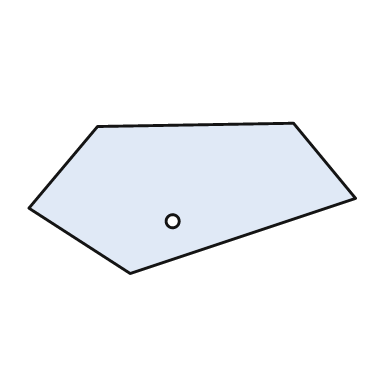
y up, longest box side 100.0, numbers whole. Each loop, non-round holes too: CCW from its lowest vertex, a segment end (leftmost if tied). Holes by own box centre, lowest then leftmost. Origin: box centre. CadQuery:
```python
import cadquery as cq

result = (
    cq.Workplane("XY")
    .moveTo(-19.0, -23.0)
    .lineTo(50.0, 0.0)
    .lineTo(31.0, 23.0)
    .lineTo(-29.0, 22.0)
    .lineTo(-50.0, -3.0)
    .close()
    .moveTo(-6.0, -7.0)
    .circle(2.0)
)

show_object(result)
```